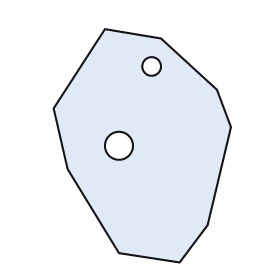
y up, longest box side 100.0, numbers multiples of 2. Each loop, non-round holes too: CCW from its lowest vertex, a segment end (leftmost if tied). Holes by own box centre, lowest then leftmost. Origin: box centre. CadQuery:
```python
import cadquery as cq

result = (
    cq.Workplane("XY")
    .moveTo(16.0, -50.0)
    .lineTo(28.0, -34.0)
    .lineTo(38.0, 8.0)
    .lineTo(32.0, 24.0)
    .lineTo(8.0, 46.0)
    .lineTo(-16.0, 50.0)
    .lineTo(-38.0, 16.0)
    .lineTo(-32.0, -10.0)
    .lineTo(-10.0, -46.0)
    .close()
    .moveTo(-10.0, 0.0)
    .circle(6.0)
    .moveTo(4.0, 34.0)
    .circle(4.0)
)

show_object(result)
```